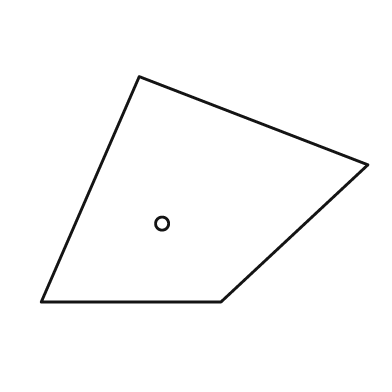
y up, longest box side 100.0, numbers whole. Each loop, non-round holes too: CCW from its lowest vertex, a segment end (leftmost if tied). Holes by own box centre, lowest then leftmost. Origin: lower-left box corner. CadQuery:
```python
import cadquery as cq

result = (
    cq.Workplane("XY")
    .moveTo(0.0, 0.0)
    .lineTo(55.0, 0.0)
    .lineTo(100.0, 42.0)
    .lineTo(30.0, 69.0)
    .close()
    .moveTo(37.0, 24.0)
    .circle(2.0)
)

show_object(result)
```